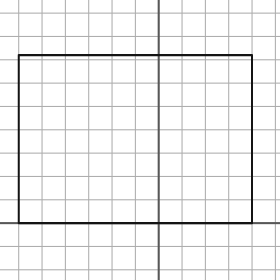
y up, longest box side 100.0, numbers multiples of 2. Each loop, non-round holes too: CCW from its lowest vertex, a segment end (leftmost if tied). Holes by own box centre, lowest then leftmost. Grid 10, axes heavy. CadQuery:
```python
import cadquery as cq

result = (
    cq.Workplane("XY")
    .moveTo(-60.0, 0.0)
    .lineTo(40.0, 0.0)
    .lineTo(40.0, 72.0)
    .lineTo(-60.0, 72.0)
    .close()
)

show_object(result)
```